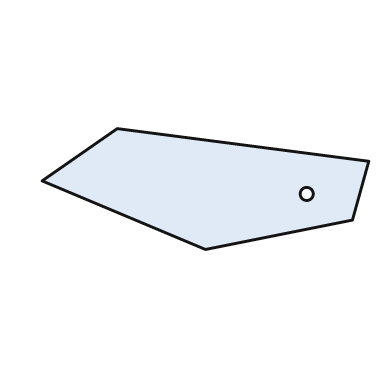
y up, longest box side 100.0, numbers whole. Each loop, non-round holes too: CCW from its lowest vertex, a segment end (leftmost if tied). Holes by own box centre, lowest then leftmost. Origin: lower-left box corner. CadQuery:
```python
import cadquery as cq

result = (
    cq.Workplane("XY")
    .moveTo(50.0, 0.0)
    .lineTo(95.0, 9.0)
    .lineTo(100.0, 27.0)
    .lineTo(23.0, 37.0)
    .lineTo(0.0, 21.0)
    .close()
    .moveTo(81.0, 17.0)
    .circle(2.0)
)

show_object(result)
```